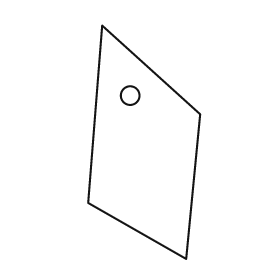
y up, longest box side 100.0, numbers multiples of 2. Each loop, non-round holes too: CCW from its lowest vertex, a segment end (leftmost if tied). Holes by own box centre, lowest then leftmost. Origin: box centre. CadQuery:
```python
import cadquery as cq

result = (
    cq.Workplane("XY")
    .moveTo(18.0, -50.0)
    .lineTo(24.0, 12.0)
    .lineTo(-18.0, 50.0)
    .lineTo(-24.0, -26.0)
    .close()
    .moveTo(-6.0, 20.0)
    .circle(4.0)
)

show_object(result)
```